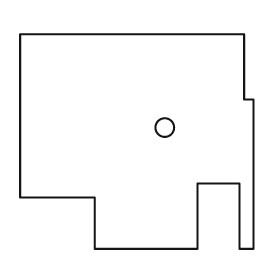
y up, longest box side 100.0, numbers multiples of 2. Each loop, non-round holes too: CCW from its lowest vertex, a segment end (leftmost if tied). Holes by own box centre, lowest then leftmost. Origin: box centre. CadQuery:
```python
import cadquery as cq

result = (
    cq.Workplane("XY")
    .moveTo(-18.0, -46.0)
    .lineTo(26.0, -46.0)
    .lineTo(26.0, -18.0)
    .lineTo(44.0, -18.0)
    .lineTo(44.0, -46.0)
    .lineTo(50.0, -46.0)
    .lineTo(50.0, 18.0)
    .lineTo(46.0, 18.0)
    .lineTo(46.0, 46.0)
    .lineTo(-50.0, 46.0)
    .lineTo(-50.0, -24.0)
    .lineTo(-18.0, -24.0)
    .close()
    .moveTo(12.0, 6.0)
    .circle(4.0)
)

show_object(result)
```